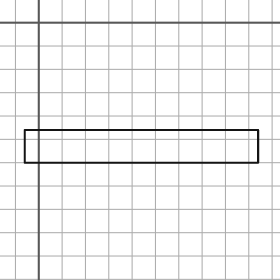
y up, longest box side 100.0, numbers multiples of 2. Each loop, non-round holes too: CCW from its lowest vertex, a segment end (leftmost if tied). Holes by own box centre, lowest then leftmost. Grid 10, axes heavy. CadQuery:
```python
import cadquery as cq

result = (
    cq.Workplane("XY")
    .moveTo(-6.0, -60.0)
    .lineTo(94.0, -60.0)
    .lineTo(94.0, -46.0)
    .lineTo(-6.0, -46.0)
    .close()
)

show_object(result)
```